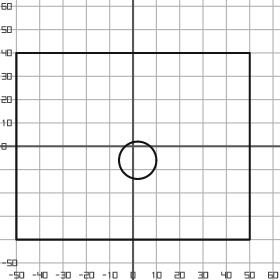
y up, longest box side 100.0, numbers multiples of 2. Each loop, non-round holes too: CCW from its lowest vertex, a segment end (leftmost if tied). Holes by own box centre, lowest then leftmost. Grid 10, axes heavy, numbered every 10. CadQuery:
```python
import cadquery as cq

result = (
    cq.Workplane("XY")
    .moveTo(-50.0, -40.0)
    .lineTo(50.0, -40.0)
    .lineTo(50.0, 40.0)
    .lineTo(-50.0, 40.0)
    .close()
    .moveTo(2.0, -6.0)
    .circle(8.0)
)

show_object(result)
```